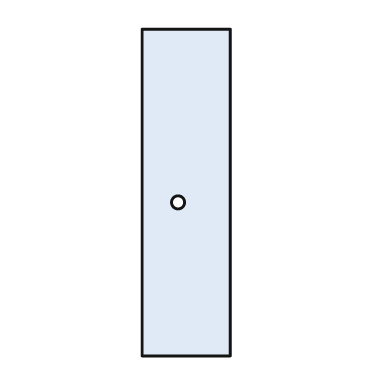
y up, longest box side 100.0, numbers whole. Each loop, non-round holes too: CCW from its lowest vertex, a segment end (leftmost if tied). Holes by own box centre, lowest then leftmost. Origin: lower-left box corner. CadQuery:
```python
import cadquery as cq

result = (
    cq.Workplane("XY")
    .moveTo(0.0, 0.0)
    .lineTo(27.0, 0.0)
    .lineTo(27.0, 100.0)
    .lineTo(0.0, 100.0)
    .close()
    .moveTo(11.0, 47.0)
    .circle(2.0)
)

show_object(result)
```